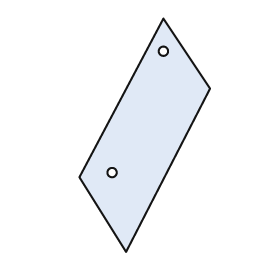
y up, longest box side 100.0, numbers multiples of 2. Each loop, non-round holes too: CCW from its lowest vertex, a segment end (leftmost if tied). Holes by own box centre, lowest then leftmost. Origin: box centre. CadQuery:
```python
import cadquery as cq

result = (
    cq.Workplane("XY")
    .moveTo(-8.0, -50.0)
    .lineTo(28.0, 20.0)
    .lineTo(8.0, 50.0)
    .lineTo(-28.0, -18.0)
    .close()
    .moveTo(-14.0, -16.0)
    .circle(2.0)
    .moveTo(8.0, 36.0)
    .circle(2.0)
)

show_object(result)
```